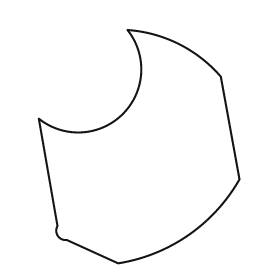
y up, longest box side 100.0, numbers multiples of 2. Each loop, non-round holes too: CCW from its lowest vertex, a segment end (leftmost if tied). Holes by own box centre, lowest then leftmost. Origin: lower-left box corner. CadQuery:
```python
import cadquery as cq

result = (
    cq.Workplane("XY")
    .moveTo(34.0, 0.0)
    .threePointArc((64.0, 12.0), (86.0, 36.0))
    .lineTo(78.0, 80.0)
    .threePointArc((60.0, 94.0), (38.0, 100.0))
    .threePointArc((36.0, 64.0), (0.0, 62.0))
    .lineTo(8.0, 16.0)
    .threePointArc((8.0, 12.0), (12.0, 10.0))
    .close()
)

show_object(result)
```